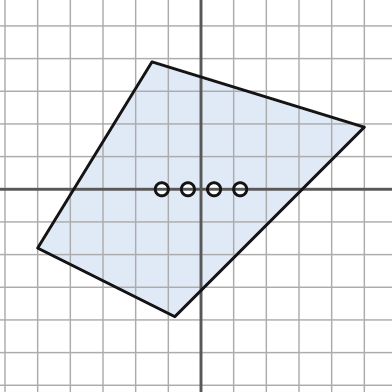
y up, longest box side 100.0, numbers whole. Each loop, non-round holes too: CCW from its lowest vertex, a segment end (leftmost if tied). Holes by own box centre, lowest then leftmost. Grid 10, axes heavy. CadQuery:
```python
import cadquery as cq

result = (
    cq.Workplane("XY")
    .moveTo(-8.0, -39.0)
    .lineTo(50.0, 19.0)
    .lineTo(-15.0, 39.0)
    .lineTo(-50.0, -18.0)
    .close()
    .moveTo(-12.0, 0.0)
    .circle(2.0)
    .moveTo(-4.0, 0.0)
    .circle(2.0)
    .moveTo(4.0, 0.0)
    .circle(2.0)
    .moveTo(12.0, 0.0)
    .circle(2.0)
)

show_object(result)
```